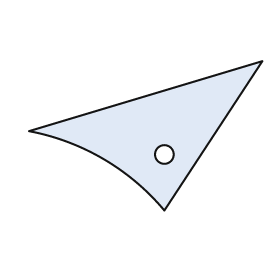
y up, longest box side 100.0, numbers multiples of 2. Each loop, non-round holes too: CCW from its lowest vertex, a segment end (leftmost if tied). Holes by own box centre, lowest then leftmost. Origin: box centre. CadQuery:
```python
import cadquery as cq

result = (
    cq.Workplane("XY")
    .moveTo(8.0, -32.0)
    .lineTo(50.0, 32.0)
    .lineTo(-50.0, 2.0)
    .threePointArc((-18.0, -10.0), (8.0, -32.0))
    .close()
    .moveTo(8.0, -8.0)
    .circle(4.0)
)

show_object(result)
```